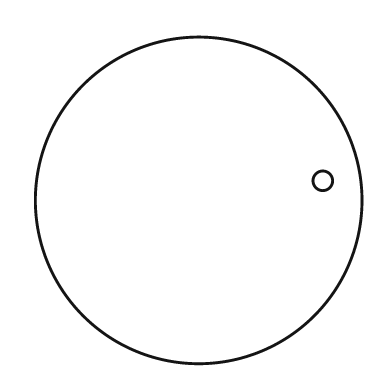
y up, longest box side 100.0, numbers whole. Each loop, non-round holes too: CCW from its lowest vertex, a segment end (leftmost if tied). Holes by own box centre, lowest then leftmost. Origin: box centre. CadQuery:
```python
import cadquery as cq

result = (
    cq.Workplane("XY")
    .moveTo(0.0, 0.0)
    .circle(50.0)
    .moveTo(38.0, 6.0)
    .circle(3.0)
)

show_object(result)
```